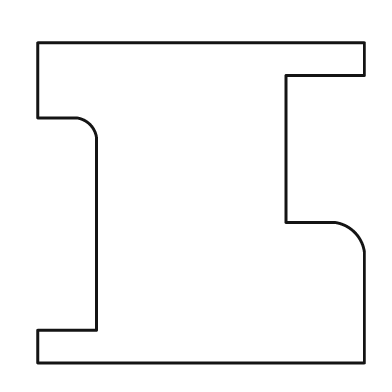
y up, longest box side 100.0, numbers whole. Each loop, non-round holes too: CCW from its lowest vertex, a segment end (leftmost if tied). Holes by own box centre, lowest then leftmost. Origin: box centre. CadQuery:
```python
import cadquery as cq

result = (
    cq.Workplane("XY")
    .moveTo(-50.0, -49.0)
    .lineTo(50.0, -49.0)
    .lineTo(50.0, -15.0)
    .threePointArc((47.0, -9.0), (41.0, -6.0))
    .lineTo(26.0, -6.0)
    .lineTo(26.0, 39.0)
    .lineTo(50.0, 39.0)
    .lineTo(50.0, 49.0)
    .lineTo(-50.0, 49.0)
    .lineTo(-50.0, 26.0)
    .lineTo(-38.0, 26.0)
    .threePointArc((-34.0, 24.0), (-32.0, 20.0))
    .lineTo(-32.0, -39.0)
    .lineTo(-50.0, -39.0)
    .close()
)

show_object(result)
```